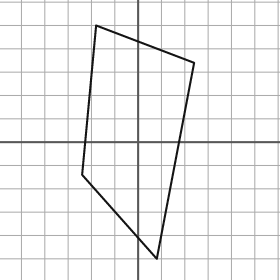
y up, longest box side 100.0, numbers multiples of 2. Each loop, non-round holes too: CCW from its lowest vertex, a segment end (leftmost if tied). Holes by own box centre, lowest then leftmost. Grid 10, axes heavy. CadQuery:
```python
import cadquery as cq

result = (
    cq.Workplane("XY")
    .moveTo(8.0, -50.0)
    .lineTo(24.0, 34.0)
    .lineTo(-18.0, 50.0)
    .lineTo(-24.0, -14.0)
    .close()
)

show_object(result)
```